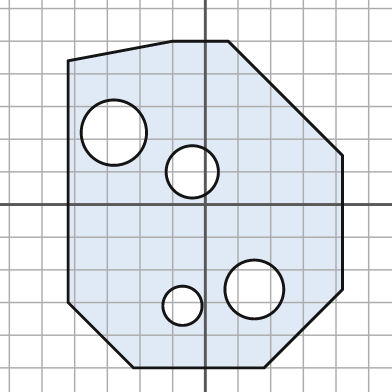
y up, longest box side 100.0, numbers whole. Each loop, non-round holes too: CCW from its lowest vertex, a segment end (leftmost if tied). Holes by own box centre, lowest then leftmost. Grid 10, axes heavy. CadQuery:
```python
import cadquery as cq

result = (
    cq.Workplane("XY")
    .moveTo(-22.0, -50.0)
    .lineTo(18.0, -50.0)
    .lineTo(42.0, -26.0)
    .lineTo(42.0, 15.0)
    .lineTo(7.0, 50.0)
    .lineTo(-10.0, 50.0)
    .lineTo(-42.0, 44.0)
    .lineTo(-42.0, -30.0)
    .close()
    .moveTo(-7.0, -31.0)
    .circle(6.0)
    .moveTo(15.0, -26.0)
    .circle(9.0)
    .moveTo(-4.0, 10.0)
    .circle(8.0)
    .moveTo(-28.0, 22.0)
    .circle(10.0)
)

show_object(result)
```